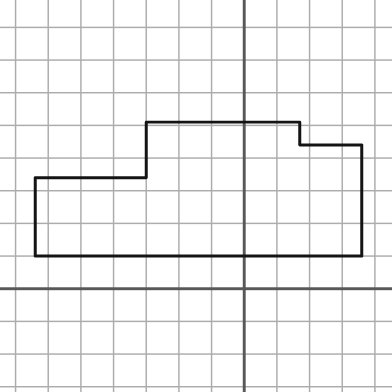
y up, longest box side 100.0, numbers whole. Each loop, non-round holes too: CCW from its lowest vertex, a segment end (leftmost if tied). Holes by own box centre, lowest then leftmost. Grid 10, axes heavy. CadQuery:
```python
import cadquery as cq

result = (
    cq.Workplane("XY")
    .moveTo(-64.0, 10.0)
    .lineTo(36.0, 10.0)
    .lineTo(36.0, 44.0)
    .lineTo(17.0, 44.0)
    .lineTo(17.0, 51.0)
    .lineTo(-30.0, 51.0)
    .lineTo(-30.0, 34.0)
    .lineTo(-64.0, 34.0)
    .close()
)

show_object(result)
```